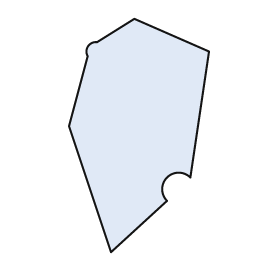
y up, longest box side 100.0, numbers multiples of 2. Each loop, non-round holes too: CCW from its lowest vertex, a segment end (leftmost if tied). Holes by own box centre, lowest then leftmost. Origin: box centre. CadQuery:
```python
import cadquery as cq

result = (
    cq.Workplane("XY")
    .moveTo(-12.0, -50.0)
    .lineTo(12.0, -28.0)
    .threePointArc((12.0, -18.0), (22.0, -18.0))
    .lineTo(30.0, 36.0)
    .lineTo(-2.0, 50.0)
    .lineTo(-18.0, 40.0)
    .threePointArc((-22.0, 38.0), (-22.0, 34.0))
    .lineTo(-30.0, 4.0)
    .close()
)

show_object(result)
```